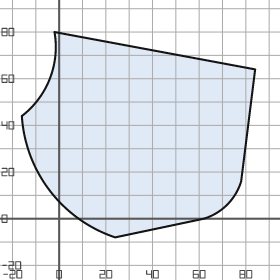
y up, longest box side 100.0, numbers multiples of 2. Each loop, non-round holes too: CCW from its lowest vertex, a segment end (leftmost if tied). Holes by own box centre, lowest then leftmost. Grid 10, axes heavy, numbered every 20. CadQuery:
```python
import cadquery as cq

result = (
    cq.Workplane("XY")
    .moveTo(24.0, -8.0)
    .lineTo(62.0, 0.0)
    .threePointArc((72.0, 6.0), (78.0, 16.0))
    .lineTo(84.0, 64.0)
    .lineTo(-2.0, 80.0)
    .threePointArc((-4.0, 60.0), (-16.0, 44.0))
    .threePointArc((-4.0, 12.0), (24.0, -8.0))
    .close()
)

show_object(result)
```